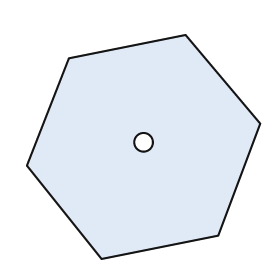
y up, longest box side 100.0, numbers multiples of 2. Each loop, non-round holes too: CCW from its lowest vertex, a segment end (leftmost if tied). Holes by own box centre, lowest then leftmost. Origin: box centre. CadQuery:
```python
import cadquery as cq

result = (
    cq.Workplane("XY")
    .moveTo(-18.0, -48.0)
    .lineTo(32.0, -38.0)
    .lineTo(50.0, 10.0)
    .lineTo(18.0, 48.0)
    .lineTo(-32.0, 38.0)
    .lineTo(-50.0, -8.0)
    .close()
    .moveTo(0.0, 2.0)
    .circle(4.0)
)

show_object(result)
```